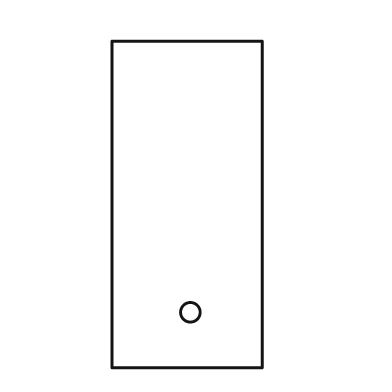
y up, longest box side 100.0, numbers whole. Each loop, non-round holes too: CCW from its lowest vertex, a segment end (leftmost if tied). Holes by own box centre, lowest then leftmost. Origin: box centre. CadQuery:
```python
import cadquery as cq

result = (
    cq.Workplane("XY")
    .moveTo(-23.0, -50.0)
    .lineTo(23.0, -50.0)
    .lineTo(23.0, 50.0)
    .lineTo(-23.0, 50.0)
    .close()
    .moveTo(1.0, -33.0)
    .circle(3.0)
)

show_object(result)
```